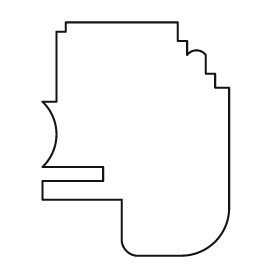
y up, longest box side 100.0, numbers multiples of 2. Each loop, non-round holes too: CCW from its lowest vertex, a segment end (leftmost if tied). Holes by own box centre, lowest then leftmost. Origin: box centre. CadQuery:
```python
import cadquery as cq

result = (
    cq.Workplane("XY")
    .moveTo(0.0, -50.0)
    .lineTo(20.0, -50.0)
    .threePointArc((34.0, -44.0), (40.0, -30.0))
    .lineTo(40.0, 22.0)
    .lineTo(34.0, 22.0)
    .lineTo(34.0, 28.0)
    .lineTo(30.0, 28.0)
    .lineTo(30.0, 36.0)
    .threePointArc((26.0, 38.0), (22.0, 36.0))
    .lineTo(22.0, 42.0)
    .lineTo(18.0, 42.0)
    .lineTo(18.0, 50.0)
    .lineTo(-30.0, 50.0)
    .lineTo(-30.0, 46.0)
    .lineTo(-34.0, 46.0)
    .lineTo(-34.0, 16.0)
    .lineTo(-40.0, 16.0)
    .threePointArc((-34.0, 2.0), (-40.0, -12.0))
    .lineTo(-14.0, -12.0)
    .lineTo(-14.0, -18.0)
    .lineTo(-40.0, -18.0)
    .lineTo(-40.0, -26.0)
    .lineTo(-6.0, -26.0)
    .lineTo(-6.0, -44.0)
    .threePointArc((-4.0, -48.0), (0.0, -50.0))
    .close()
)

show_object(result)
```